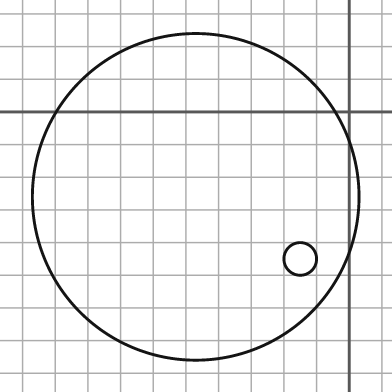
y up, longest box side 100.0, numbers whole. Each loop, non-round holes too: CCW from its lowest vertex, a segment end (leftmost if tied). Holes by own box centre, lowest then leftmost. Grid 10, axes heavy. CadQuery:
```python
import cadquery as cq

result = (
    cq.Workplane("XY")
    .moveTo(-47.0, -26.0)
    .circle(50.0)
    .moveTo(-15.0, -45.0)
    .circle(5.0)
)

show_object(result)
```